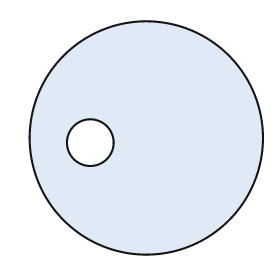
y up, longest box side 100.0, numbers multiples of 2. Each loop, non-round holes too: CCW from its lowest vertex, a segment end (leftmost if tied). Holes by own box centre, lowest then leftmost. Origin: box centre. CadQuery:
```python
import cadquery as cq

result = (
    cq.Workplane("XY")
    .moveTo(0.0, 0.0)
    .circle(50.0)
    .moveTo(-24.0, -2.0)
    .circle(10.0)
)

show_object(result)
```